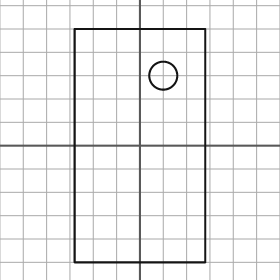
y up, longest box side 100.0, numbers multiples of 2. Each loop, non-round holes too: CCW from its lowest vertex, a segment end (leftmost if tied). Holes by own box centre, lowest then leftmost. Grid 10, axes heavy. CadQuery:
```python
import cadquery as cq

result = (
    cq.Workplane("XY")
    .moveTo(-28.0, -50.0)
    .lineTo(28.0, -50.0)
    .lineTo(28.0, 50.0)
    .lineTo(-28.0, 50.0)
    .close()
    .moveTo(10.0, 30.0)
    .circle(6.0)
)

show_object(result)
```